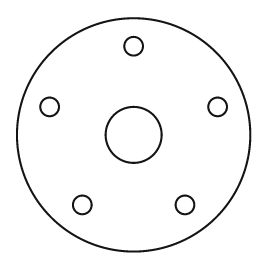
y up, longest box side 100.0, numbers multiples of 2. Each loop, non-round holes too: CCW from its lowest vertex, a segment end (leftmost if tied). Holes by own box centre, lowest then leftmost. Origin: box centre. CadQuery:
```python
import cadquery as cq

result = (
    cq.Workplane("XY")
    .moveTo(0.0, 0.0)
    .circle(50.0)
    .moveTo(-22.0, -30.0)
    .circle(4.0)
    .moveTo(22.0, -30.0)
    .circle(4.0)
    .moveTo(0.0, 0.0)
    .circle(12.0)
    .moveTo(-36.0, 12.0)
    .circle(4.0)
    .moveTo(36.0, 12.0)
    .circle(4.0)
    .moveTo(0.0, 38.0)
    .circle(4.0)
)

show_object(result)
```